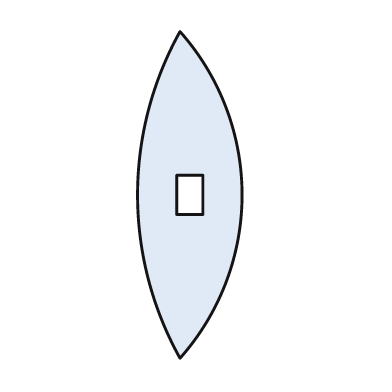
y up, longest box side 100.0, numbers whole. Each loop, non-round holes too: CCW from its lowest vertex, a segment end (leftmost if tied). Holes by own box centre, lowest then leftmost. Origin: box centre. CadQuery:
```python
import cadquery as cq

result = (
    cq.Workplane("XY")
    .moveTo(-3.0, -50.0)
    .threePointArc((16.0, 0.0), (-3.0, 50.0))
    .threePointArc((-16.0, 0.0), (-3.0, -50.0))
    .close()
    .moveTo(-4.0, -6.0)
    .lineTo(4.0, -6.0)
    .lineTo(4.0, 6.0)
    .lineTo(-4.0, 6.0)
    .close()
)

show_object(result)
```